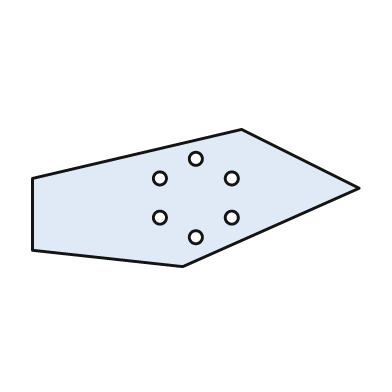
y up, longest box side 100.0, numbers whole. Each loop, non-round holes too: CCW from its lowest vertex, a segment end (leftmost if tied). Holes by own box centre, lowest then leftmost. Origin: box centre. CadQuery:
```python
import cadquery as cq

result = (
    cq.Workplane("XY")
    .moveTo(-4.0, -21.0)
    .lineTo(50.0, 3.0)
    .lineTo(14.0, 21.0)
    .lineTo(-50.0, 6.0)
    .lineTo(-50.0, -16.0)
    .close()
    .moveTo(0.0, -12.0)
    .circle(2.0)
    .moveTo(-11.0, -6.0)
    .circle(2.0)
    .moveTo(11.0, -6.0)
    .circle(2.0)
    .moveTo(-11.0, 6.0)
    .circle(2.0)
    .moveTo(11.0, 6.0)
    .circle(2.0)
    .moveTo(0.0, 12.0)
    .circle(2.0)
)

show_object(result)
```